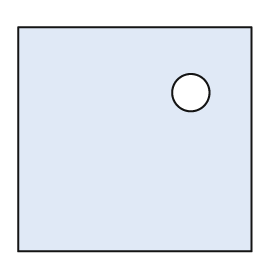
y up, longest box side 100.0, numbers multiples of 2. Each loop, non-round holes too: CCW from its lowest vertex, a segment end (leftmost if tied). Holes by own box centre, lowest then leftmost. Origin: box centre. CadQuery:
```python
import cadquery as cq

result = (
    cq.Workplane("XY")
    .moveTo(-50.0, -48.0)
    .lineTo(50.0, -48.0)
    .lineTo(50.0, 48.0)
    .lineTo(-50.0, 48.0)
    .close()
    .moveTo(24.0, 20.0)
    .circle(8.0)
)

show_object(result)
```